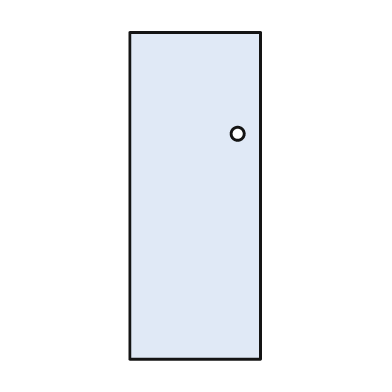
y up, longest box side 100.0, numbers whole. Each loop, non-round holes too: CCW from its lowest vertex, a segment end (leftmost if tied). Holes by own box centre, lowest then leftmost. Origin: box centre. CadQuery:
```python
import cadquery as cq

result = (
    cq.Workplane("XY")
    .moveTo(-20.0, -50.0)
    .lineTo(20.0, -50.0)
    .lineTo(20.0, 50.0)
    .lineTo(-20.0, 50.0)
    .close()
    .moveTo(13.0, 19.0)
    .circle(2.0)
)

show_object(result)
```